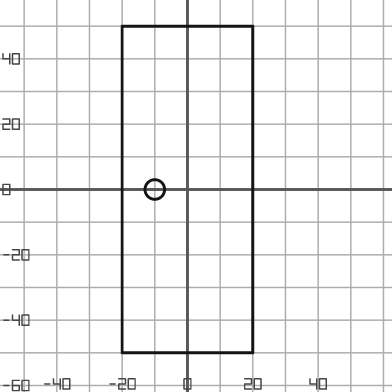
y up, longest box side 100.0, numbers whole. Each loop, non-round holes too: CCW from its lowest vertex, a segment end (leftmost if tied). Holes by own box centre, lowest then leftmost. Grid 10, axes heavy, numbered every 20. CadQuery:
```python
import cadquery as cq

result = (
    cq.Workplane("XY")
    .moveTo(-20.0, -50.0)
    .lineTo(20.0, -50.0)
    .lineTo(20.0, 50.0)
    .lineTo(-20.0, 50.0)
    .close()
    .moveTo(-10.0, 0.0)
    .circle(3.0)
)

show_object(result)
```